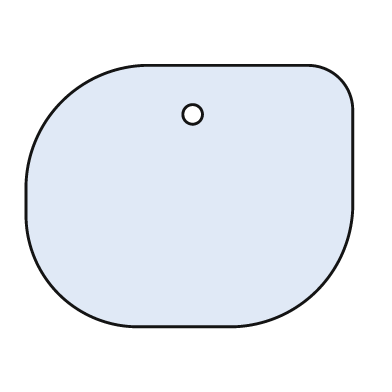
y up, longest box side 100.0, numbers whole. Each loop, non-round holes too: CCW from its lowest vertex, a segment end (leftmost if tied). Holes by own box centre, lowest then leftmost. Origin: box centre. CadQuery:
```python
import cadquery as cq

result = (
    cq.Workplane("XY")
    .moveTo(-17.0, -40.0)
    .lineTo(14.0, -40.0)
    .threePointArc((39.0, -29.0), (50.0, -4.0))
    .lineTo(50.0, 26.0)
    .threePointArc((46.0, 36.0), (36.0, 40.0))
    .lineTo(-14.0, 40.0)
    .threePointArc((-39.0, 29.0), (-50.0, 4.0))
    .lineTo(-50.0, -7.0)
    .threePointArc((-40.0, -30.0), (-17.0, -40.0))
    .close()
    .moveTo(1.0, 25.0)
    .circle(3.0)
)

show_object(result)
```